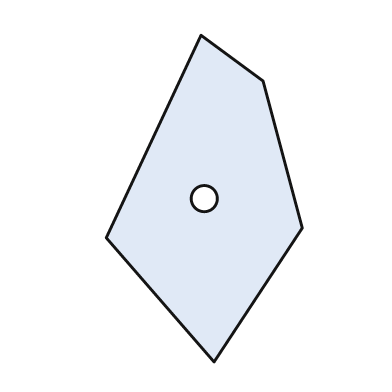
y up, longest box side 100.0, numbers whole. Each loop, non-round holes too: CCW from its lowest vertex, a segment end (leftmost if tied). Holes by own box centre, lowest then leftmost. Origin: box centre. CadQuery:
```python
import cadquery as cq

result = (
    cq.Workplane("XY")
    .moveTo(3.0, -50.0)
    .lineTo(30.0, -9.0)
    .lineTo(18.0, 36.0)
    .lineTo(-1.0, 50.0)
    .lineTo(-30.0, -12.0)
    .close()
    .moveTo(0.0, 0.0)
    .circle(4.0)
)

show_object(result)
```